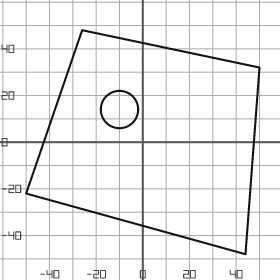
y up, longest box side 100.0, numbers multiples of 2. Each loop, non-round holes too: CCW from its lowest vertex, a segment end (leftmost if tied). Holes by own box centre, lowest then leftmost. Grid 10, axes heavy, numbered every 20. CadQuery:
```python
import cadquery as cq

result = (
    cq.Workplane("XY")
    .moveTo(44.0, -48.0)
    .lineTo(50.0, 32.0)
    .lineTo(-26.0, 48.0)
    .lineTo(-50.0, -22.0)
    .close()
    .moveTo(-10.0, 14.0)
    .circle(8.0)
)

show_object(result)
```